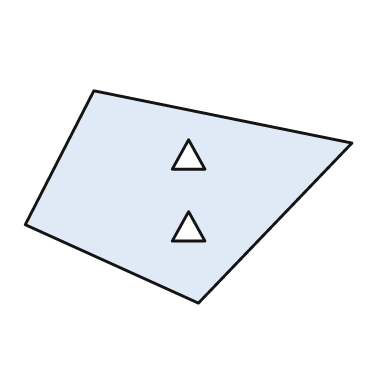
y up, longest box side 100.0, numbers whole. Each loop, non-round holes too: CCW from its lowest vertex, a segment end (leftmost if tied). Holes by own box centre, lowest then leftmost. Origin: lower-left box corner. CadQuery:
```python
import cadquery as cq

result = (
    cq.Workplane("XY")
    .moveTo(53.0, 0.0)
    .lineTo(100.0, 49.0)
    .lineTo(21.0, 65.0)
    .lineTo(0.0, 24.0)
    .close()
    .moveTo(45.0, 19.0)
    .lineTo(55.0, 19.0)
    .lineTo(50.0, 28.0)
    .close()
    .moveTo(45.0, 41.0)
    .lineTo(55.0, 41.0)
    .lineTo(50.0, 50.0)
    .close()
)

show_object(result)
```